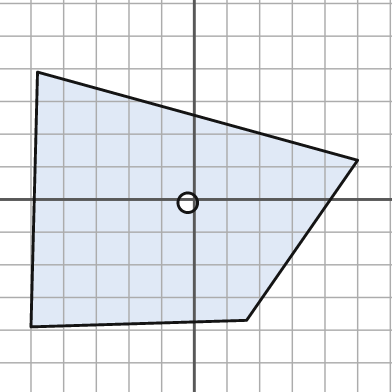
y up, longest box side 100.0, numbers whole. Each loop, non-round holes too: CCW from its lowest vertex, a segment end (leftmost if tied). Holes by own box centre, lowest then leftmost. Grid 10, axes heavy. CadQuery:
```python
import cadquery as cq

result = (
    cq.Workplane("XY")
    .moveTo(-50.0, -39.0)
    .lineTo(16.0, -37.0)
    .lineTo(50.0, 12.0)
    .lineTo(-48.0, 39.0)
    .close()
    .moveTo(-2.0, -1.0)
    .circle(3.0)
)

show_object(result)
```